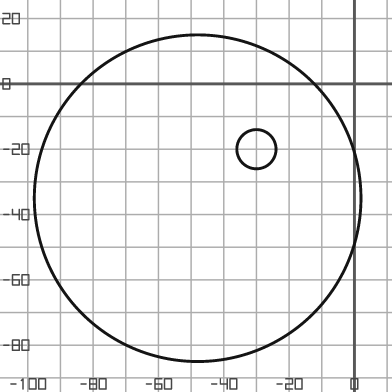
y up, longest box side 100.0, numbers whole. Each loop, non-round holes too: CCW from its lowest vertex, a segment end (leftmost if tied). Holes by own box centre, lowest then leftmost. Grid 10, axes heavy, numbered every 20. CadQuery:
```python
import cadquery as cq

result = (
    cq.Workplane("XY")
    .moveTo(-48.0, -35.0)
    .circle(50.0)
    .moveTo(-30.0, -20.0)
    .circle(6.0)
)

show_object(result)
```